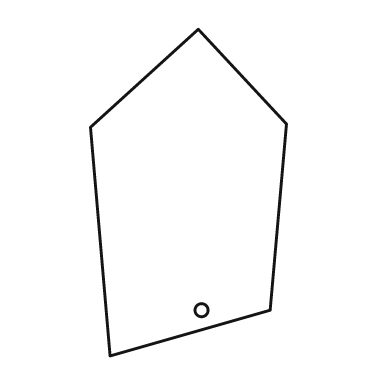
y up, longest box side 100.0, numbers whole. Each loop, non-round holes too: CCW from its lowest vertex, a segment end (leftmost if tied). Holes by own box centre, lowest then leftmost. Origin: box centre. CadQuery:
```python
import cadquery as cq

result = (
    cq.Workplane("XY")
    .moveTo(-24.0, -50.0)
    .lineTo(25.0, -36.0)
    .lineTo(30.0, 21.0)
    .lineTo(3.0, 50.0)
    .lineTo(-30.0, 20.0)
    .close()
    .moveTo(4.0, -36.0)
    .circle(2.0)
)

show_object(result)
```